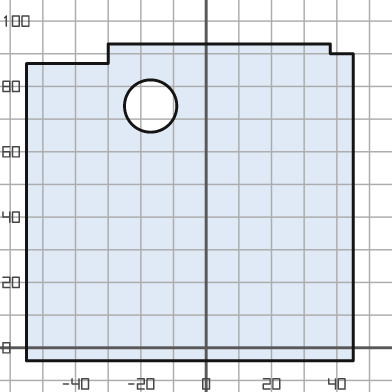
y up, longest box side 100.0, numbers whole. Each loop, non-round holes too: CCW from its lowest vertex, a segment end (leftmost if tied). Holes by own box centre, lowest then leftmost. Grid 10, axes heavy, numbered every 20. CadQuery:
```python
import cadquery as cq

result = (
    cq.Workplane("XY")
    .moveTo(-55.0, -4.0)
    .lineTo(45.0, -4.0)
    .lineTo(45.0, 90.0)
    .lineTo(38.0, 90.0)
    .lineTo(38.0, 93.0)
    .lineTo(-30.0, 93.0)
    .lineTo(-30.0, 87.0)
    .lineTo(-55.0, 87.0)
    .close()
    .moveTo(-17.0, 74.0)
    .circle(8.0)
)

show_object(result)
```